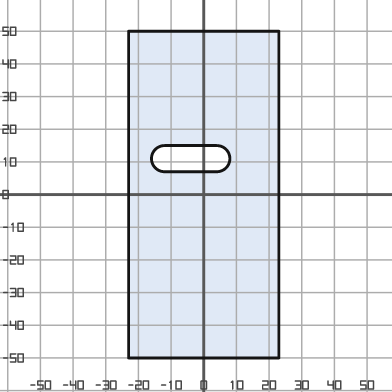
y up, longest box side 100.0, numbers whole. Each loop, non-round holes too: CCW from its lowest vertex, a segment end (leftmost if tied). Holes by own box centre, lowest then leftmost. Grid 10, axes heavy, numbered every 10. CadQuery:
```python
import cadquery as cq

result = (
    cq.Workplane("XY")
    .moveTo(-23.0, -50.0)
    .lineTo(23.0, -50.0)
    .lineTo(23.0, 50.0)
    .lineTo(-23.0, 50.0)
    .close()
    .moveTo(-12.0, 7.0)
    .lineTo(4.0, 7.0)
    .threePointArc((8.0, 11.0), (4.0, 15.0))
    .lineTo(-12.0, 15.0)
    .threePointArc((-16.0, 11.0), (-12.0, 7.0))
    .close()
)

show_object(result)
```